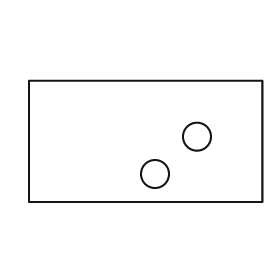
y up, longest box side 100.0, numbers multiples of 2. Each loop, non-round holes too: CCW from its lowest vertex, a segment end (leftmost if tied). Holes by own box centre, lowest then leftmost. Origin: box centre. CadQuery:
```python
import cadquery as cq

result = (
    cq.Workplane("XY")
    .moveTo(-50.0, -26.0)
    .lineTo(50.0, -26.0)
    .lineTo(50.0, 26.0)
    .lineTo(-50.0, 26.0)
    .close()
    .moveTo(4.0, -14.0)
    .circle(6.0)
    .moveTo(22.0, 2.0)
    .circle(6.0)
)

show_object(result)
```